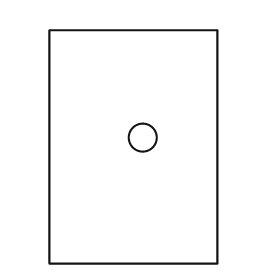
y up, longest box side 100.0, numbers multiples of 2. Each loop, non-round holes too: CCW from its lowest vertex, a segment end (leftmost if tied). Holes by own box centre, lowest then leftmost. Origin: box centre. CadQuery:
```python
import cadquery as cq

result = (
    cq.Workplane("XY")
    .moveTo(-36.0, -50.0)
    .lineTo(36.0, -50.0)
    .lineTo(36.0, 50.0)
    .lineTo(-36.0, 50.0)
    .close()
    .moveTo(4.0, 4.0)
    .circle(6.0)
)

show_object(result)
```